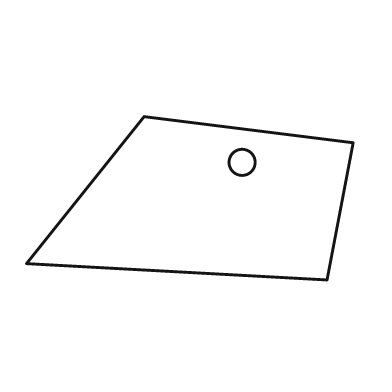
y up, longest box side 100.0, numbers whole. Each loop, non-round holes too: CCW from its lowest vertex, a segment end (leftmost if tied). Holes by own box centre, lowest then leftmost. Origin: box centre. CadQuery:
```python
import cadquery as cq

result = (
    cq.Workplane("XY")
    .moveTo(42.0, -25.0)
    .lineTo(50.0, 17.0)
    .lineTo(-14.0, 25.0)
    .lineTo(-50.0, -20.0)
    .close()
    .moveTo(16.0, 11.0)
    .circle(4.0)
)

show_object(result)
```